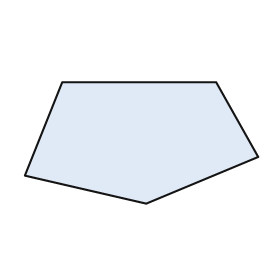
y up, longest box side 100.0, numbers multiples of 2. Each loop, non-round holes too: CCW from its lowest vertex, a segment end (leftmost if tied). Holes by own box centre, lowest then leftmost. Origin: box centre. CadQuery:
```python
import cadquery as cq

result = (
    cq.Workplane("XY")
    .moveTo(2.0, -26.0)
    .lineTo(50.0, -6.0)
    .lineTo(32.0, 26.0)
    .lineTo(-34.0, 26.0)
    .lineTo(-50.0, -14.0)
    .close()
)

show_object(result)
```